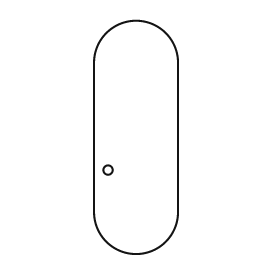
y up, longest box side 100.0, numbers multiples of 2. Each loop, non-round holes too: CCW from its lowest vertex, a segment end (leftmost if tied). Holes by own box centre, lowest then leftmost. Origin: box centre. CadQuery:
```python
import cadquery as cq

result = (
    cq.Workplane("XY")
    .moveTo(-18.0, -32.0)
    .threePointArc((0.0, -50.0), (18.0, -32.0))
    .lineTo(18.0, 32.0)
    .threePointArc((0.0, 50.0), (-18.0, 32.0))
    .close()
    .moveTo(-12.0, -14.0)
    .circle(2.0)
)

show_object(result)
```